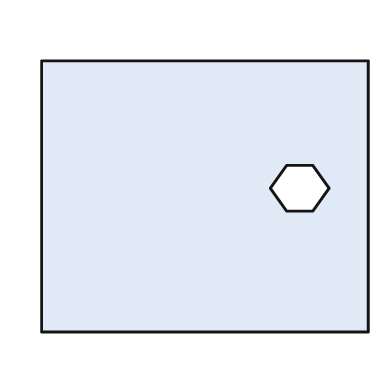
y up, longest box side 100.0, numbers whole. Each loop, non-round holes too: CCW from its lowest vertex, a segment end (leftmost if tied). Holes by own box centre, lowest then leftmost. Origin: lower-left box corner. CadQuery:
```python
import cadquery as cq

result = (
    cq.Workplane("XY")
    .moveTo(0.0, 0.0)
    .lineTo(100.0, 0.0)
    .lineTo(100.0, 83.0)
    .lineTo(0.0, 83.0)
    .close()
    .moveTo(75.0, 37.0)
    .lineTo(83.0, 37.0)
    .lineTo(88.0, 44.0)
    .lineTo(83.0, 51.0)
    .lineTo(75.0, 51.0)
    .lineTo(70.0, 44.0)
    .close()
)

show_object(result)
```